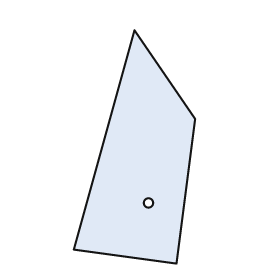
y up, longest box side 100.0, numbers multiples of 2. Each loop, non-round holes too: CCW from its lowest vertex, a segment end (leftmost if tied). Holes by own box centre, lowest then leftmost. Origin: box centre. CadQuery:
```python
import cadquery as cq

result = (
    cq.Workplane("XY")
    .moveTo(18.0, -50.0)
    .lineTo(26.0, 12.0)
    .lineTo(0.0, 50.0)
    .lineTo(-26.0, -44.0)
    .close()
    .moveTo(6.0, -24.0)
    .circle(2.0)
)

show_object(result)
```